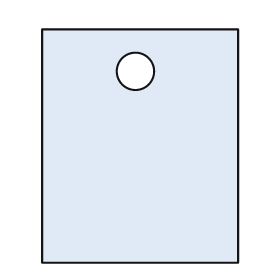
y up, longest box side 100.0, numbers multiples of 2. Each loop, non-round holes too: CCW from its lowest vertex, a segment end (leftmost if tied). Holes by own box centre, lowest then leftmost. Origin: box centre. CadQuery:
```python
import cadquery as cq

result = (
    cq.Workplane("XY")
    .moveTo(-42.0, -50.0)
    .lineTo(42.0, -50.0)
    .lineTo(42.0, 50.0)
    .lineTo(-42.0, 50.0)
    .close()
    .moveTo(-2.0, 32.0)
    .circle(8.0)
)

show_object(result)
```